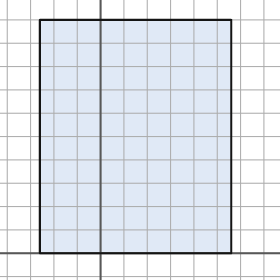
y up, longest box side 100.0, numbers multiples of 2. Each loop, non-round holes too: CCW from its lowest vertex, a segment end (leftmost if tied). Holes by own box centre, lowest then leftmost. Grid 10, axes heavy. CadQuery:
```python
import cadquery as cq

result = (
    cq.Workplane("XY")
    .moveTo(-26.0, 0.0)
    .lineTo(56.0, 0.0)
    .lineTo(56.0, 100.0)
    .lineTo(-26.0, 100.0)
    .close()
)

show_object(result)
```